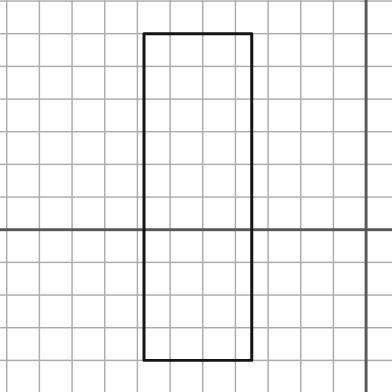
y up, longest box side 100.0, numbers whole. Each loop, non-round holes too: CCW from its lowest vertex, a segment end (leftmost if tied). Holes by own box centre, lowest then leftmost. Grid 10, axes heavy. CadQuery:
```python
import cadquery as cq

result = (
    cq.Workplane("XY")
    .moveTo(-68.0, -40.0)
    .lineTo(-35.0, -40.0)
    .lineTo(-35.0, 60.0)
    .lineTo(-68.0, 60.0)
    .close()
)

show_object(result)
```